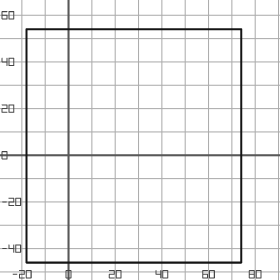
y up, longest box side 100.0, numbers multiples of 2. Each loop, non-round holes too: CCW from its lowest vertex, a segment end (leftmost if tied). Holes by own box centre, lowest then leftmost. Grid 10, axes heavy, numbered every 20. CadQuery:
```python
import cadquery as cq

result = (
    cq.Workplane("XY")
    .moveTo(-18.0, -46.0)
    .lineTo(74.0, -46.0)
    .lineTo(74.0, 54.0)
    .lineTo(-18.0, 54.0)
    .close()
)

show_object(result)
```